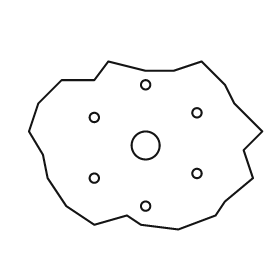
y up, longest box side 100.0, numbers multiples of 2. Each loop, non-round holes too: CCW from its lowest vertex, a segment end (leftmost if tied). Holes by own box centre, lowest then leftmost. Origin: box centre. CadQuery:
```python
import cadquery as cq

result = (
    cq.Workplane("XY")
    .moveTo(14.0, -36.0)
    .lineTo(30.0, -30.0)
    .lineTo(34.0, -24.0)
    .lineTo(46.0, -14.0)
    .lineTo(42.0, -2.0)
    .lineTo(50.0, 6.0)
    .lineTo(38.0, 18.0)
    .lineTo(34.0, 26.0)
    .lineTo(24.0, 36.0)
    .lineTo(12.0, 32.0)
    .lineTo(0.0, 32.0)
    .lineTo(-16.0, 36.0)
    .lineTo(-22.0, 28.0)
    .lineTo(-36.0, 28.0)
    .lineTo(-46.0, 18.0)
    .lineTo(-50.0, 6.0)
    .lineTo(-44.0, -4.0)
    .lineTo(-42.0, -14.0)
    .lineTo(-34.0, -26.0)
    .lineTo(-22.0, -34.0)
    .lineTo(-8.0, -30.0)
    .lineTo(-2.0, -34.0)
    .close()
    .moveTo(0.0, -26.0)
    .circle(2.0)
    .moveTo(-22.0, -14.0)
    .circle(2.0)
    .moveTo(22.0, -12.0)
    .circle(2.0)
    .moveTo(0.0, 0.0)
    .circle(6.0)
    .moveTo(-22.0, 12.0)
    .circle(2.0)
    .moveTo(22.0, 14.0)
    .circle(2.0)
    .moveTo(0.0, 26.0)
    .circle(2.0)
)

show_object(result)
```